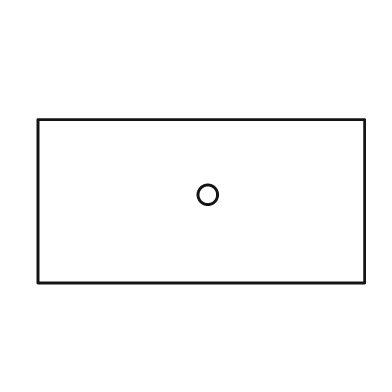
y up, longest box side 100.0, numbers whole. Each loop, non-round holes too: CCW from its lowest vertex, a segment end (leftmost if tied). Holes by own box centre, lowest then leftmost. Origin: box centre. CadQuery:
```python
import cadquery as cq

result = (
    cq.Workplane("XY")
    .moveTo(-50.0, -25.0)
    .lineTo(50.0, -25.0)
    .lineTo(50.0, 25.0)
    .lineTo(-50.0, 25.0)
    .close()
    .moveTo(2.0, 2.0)
    .circle(3.0)
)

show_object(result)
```